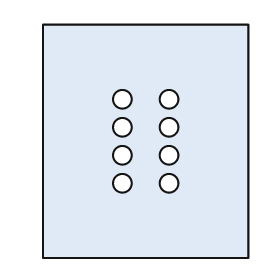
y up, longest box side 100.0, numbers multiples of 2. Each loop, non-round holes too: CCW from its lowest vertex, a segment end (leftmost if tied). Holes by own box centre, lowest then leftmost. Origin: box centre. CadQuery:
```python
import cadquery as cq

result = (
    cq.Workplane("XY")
    .moveTo(-44.0, -50.0)
    .lineTo(44.0, -50.0)
    .lineTo(44.0, 50.0)
    .lineTo(-44.0, 50.0)
    .close()
    .moveTo(-10.0, -18.0)
    .circle(4.0)
    .moveTo(10.0, -18.0)
    .circle(4.0)
    .moveTo(-10.0, -6.0)
    .circle(4.0)
    .moveTo(10.0, -6.0)
    .circle(4.0)
    .moveTo(-10.0, 6.0)
    .circle(4.0)
    .moveTo(10.0, 6.0)
    .circle(4.0)
    .moveTo(-10.0, 18.0)
    .circle(4.0)
    .moveTo(10.0, 18.0)
    .circle(4.0)
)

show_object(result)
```